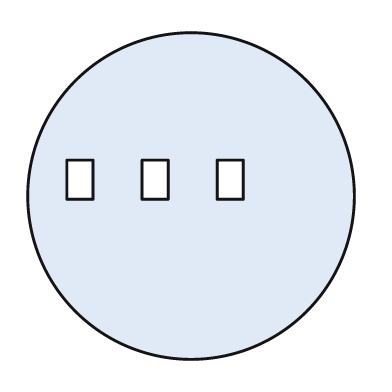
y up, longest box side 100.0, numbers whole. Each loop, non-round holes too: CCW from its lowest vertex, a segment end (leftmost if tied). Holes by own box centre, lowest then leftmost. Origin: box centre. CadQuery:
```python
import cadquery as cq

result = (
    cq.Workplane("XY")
    .moveTo(0.0, 0.0)
    .circle(50.0)
    .moveTo(-38.0, -1.0)
    .lineTo(-30.0, -1.0)
    .lineTo(-30.0, 11.0)
    .lineTo(-38.0, 11.0)
    .close()
    .moveTo(-15.0, -1.0)
    .lineTo(-7.0, -1.0)
    .lineTo(-7.0, 11.0)
    .lineTo(-15.0, 11.0)
    .close()
    .moveTo(8.0, -1.0)
    .lineTo(16.0, -1.0)
    .lineTo(16.0, 11.0)
    .lineTo(8.0, 11.0)
    .close()
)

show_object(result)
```